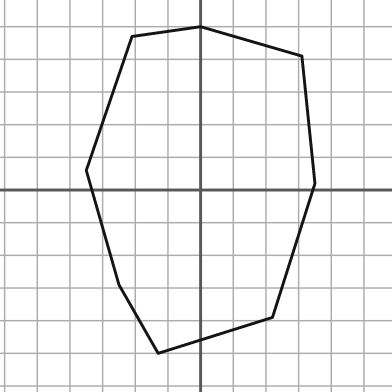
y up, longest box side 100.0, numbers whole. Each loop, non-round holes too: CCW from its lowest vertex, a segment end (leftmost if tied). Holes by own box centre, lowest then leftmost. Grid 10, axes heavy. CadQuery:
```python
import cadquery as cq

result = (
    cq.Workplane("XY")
    .moveTo(-13.0, -50.0)
    .lineTo(22.0, -39.0)
    .lineTo(35.0, 2.0)
    .lineTo(31.0, 41.0)
    .lineTo(0.0, 50.0)
    .lineTo(-21.0, 47.0)
    .lineTo(-35.0, 6.0)
    .lineTo(-25.0, -29.0)
    .close()
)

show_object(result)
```